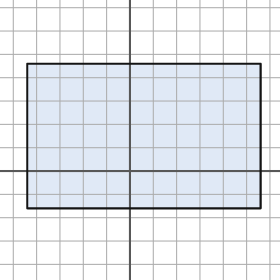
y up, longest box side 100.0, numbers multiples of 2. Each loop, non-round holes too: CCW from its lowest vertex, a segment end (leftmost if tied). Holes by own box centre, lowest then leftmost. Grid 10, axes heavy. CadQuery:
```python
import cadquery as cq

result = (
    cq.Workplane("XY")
    .moveTo(-44.0, -16.0)
    .lineTo(56.0, -16.0)
    .lineTo(56.0, 46.0)
    .lineTo(-44.0, 46.0)
    .close()
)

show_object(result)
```